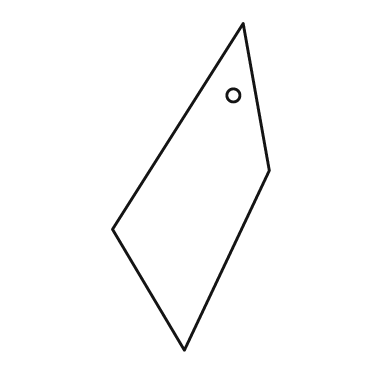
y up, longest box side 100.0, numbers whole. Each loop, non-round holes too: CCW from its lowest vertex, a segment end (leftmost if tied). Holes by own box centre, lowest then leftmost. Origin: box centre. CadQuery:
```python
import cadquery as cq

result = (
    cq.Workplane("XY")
    .moveTo(-2.0, -50.0)
    .lineTo(24.0, 5.0)
    .lineTo(16.0, 50.0)
    .lineTo(-24.0, -13.0)
    .close()
    .moveTo(13.0, 28.0)
    .circle(2.0)
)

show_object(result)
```